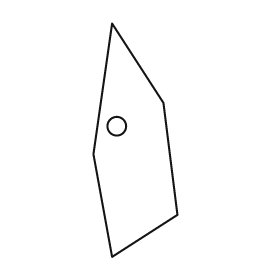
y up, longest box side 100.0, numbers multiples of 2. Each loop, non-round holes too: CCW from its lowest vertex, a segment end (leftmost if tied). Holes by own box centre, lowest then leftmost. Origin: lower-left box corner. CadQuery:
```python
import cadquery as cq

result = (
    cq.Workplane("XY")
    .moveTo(8.0, 0.0)
    .lineTo(36.0, 18.0)
    .lineTo(30.0, 66.0)
    .lineTo(8.0, 100.0)
    .lineTo(0.0, 44.0)
    .close()
    .moveTo(10.0, 56.0)
    .circle(4.0)
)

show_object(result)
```